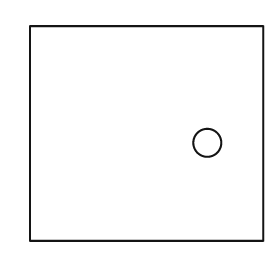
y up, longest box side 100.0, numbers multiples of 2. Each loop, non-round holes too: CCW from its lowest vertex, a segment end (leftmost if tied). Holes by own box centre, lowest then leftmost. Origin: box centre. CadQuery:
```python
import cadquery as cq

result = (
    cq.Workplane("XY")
    .moveTo(-50.0, -46.0)
    .lineTo(50.0, -46.0)
    .lineTo(50.0, 46.0)
    .lineTo(-50.0, 46.0)
    .close()
    .moveTo(26.0, -4.0)
    .circle(6.0)
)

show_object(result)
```